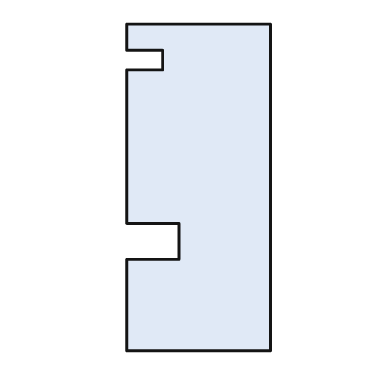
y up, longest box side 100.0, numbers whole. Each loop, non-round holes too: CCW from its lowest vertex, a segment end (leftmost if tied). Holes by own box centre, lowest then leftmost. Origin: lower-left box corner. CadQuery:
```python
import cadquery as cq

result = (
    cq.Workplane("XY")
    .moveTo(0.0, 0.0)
    .lineTo(44.0, 0.0)
    .lineTo(44.0, 100.0)
    .lineTo(0.0, 100.0)
    .lineTo(0.0, 92.0)
    .lineTo(11.0, 92.0)
    .lineTo(11.0, 86.0)
    .lineTo(0.0, 86.0)
    .lineTo(0.0, 39.0)
    .lineTo(16.0, 39.0)
    .lineTo(16.0, 28.0)
    .lineTo(0.0, 28.0)
    .close()
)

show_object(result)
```